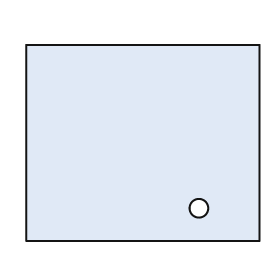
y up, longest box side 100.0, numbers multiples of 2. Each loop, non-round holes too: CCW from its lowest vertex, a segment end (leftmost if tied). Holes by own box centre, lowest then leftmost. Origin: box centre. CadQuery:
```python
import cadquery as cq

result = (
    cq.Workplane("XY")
    .moveTo(-50.0, -42.0)
    .lineTo(50.0, -42.0)
    .lineTo(50.0, 42.0)
    .lineTo(-50.0, 42.0)
    .close()
    .moveTo(24.0, -28.0)
    .circle(4.0)
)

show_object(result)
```